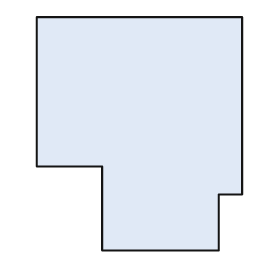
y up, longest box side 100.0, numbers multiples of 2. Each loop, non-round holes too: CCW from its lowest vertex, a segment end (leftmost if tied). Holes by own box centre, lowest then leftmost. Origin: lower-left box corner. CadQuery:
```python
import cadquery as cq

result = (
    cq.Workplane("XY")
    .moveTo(28.0, 0.0)
    .lineTo(78.0, 0.0)
    .lineTo(78.0, 24.0)
    .lineTo(88.0, 24.0)
    .lineTo(88.0, 100.0)
    .lineTo(0.0, 100.0)
    .lineTo(0.0, 36.0)
    .lineTo(28.0, 36.0)
    .close()
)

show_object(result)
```